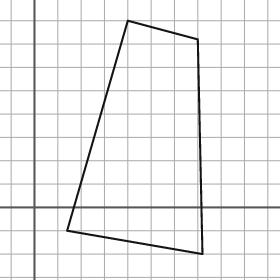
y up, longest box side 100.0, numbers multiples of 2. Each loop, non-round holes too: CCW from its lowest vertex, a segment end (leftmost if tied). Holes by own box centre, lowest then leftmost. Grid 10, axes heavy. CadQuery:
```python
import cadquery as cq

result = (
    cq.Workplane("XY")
    .moveTo(72.0, -20.0)
    .lineTo(70.0, 72.0)
    .lineTo(40.0, 80.0)
    .lineTo(14.0, -10.0)
    .close()
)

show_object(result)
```